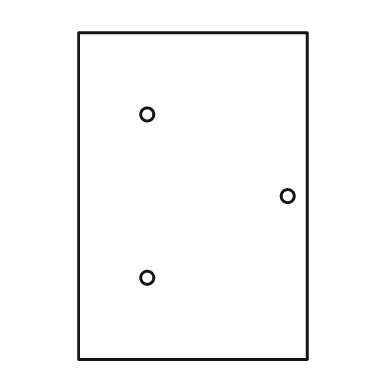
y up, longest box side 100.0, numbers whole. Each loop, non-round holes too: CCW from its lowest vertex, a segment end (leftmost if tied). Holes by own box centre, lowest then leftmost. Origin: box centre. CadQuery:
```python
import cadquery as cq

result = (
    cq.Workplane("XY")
    .moveTo(-35.0, -50.0)
    .lineTo(35.0, -50.0)
    .lineTo(35.0, 50.0)
    .lineTo(-35.0, 50.0)
    .close()
    .moveTo(-14.0, -25.0)
    .circle(2.0)
    .moveTo(29.0, 0.0)
    .circle(2.0)
    .moveTo(-14.0, 25.0)
    .circle(2.0)
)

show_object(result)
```